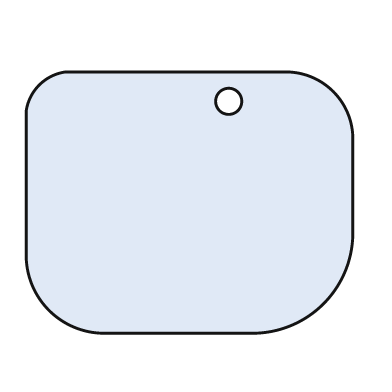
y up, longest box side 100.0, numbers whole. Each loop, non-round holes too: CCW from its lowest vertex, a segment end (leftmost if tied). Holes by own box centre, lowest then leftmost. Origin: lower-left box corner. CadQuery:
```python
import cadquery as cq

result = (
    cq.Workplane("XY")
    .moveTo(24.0, 0.0)
    .lineTo(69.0, 0.0)
    .threePointArc((91.0, 9.0), (100.0, 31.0))
    .lineTo(100.0, 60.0)
    .threePointArc((94.0, 74.0), (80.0, 80.0))
    .lineTo(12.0, 80.0)
    .threePointArc((4.0, 76.0), (0.0, 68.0))
    .lineTo(0.0, 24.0)
    .threePointArc((7.0, 7.0), (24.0, 0.0))
    .close()
    .moveTo(62.0, 71.0)
    .circle(4.0)
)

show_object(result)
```